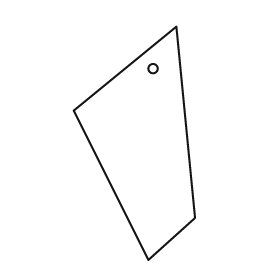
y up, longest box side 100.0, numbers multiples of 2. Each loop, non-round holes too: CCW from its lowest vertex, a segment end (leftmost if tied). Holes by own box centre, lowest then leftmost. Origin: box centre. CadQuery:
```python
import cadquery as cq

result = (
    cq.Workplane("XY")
    .moveTo(6.0, -50.0)
    .lineTo(26.0, -32.0)
    .lineTo(18.0, 50.0)
    .lineTo(-26.0, 14.0)
    .close()
    .moveTo(8.0, 32.0)
    .circle(2.0)
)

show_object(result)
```